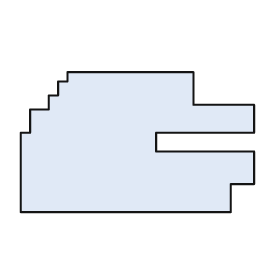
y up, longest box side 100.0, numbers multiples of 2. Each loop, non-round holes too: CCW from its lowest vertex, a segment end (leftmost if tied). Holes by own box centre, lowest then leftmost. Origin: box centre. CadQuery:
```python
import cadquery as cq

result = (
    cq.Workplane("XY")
    .moveTo(-50.0, -30.0)
    .lineTo(40.0, -30.0)
    .lineTo(40.0, -18.0)
    .lineTo(50.0, -18.0)
    .lineTo(50.0, -4.0)
    .lineTo(8.0, -4.0)
    .lineTo(8.0, 4.0)
    .lineTo(50.0, 4.0)
    .lineTo(50.0, 16.0)
    .lineTo(24.0, 16.0)
    .lineTo(24.0, 30.0)
    .lineTo(-30.0, 30.0)
    .lineTo(-30.0, 26.0)
    .lineTo(-34.0, 26.0)
    .lineTo(-34.0, 20.0)
    .lineTo(-38.0, 20.0)
    .lineTo(-38.0, 14.0)
    .lineTo(-46.0, 14.0)
    .lineTo(-46.0, 4.0)
    .lineTo(-50.0, 4.0)
    .close()
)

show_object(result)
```